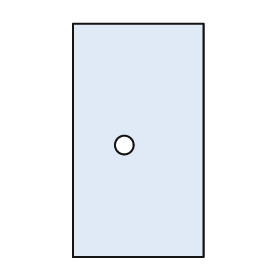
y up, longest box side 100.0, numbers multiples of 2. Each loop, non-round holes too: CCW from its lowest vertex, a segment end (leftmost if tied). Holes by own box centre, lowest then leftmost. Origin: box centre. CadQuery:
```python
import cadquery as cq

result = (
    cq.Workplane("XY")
    .moveTo(-28.0, -50.0)
    .lineTo(28.0, -50.0)
    .lineTo(28.0, 50.0)
    .lineTo(-28.0, 50.0)
    .close()
    .moveTo(-6.0, -2.0)
    .circle(4.0)
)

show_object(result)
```